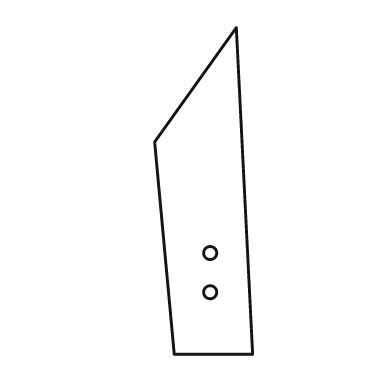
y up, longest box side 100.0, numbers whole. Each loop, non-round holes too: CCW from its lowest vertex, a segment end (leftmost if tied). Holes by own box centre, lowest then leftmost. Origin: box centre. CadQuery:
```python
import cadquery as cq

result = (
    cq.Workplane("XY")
    .moveTo(-9.0, -50.0)
    .lineTo(15.0, -50.0)
    .lineTo(10.0, 50.0)
    .lineTo(-15.0, 15.0)
    .close()
    .moveTo(2.0, -31.0)
    .circle(2.0)
    .moveTo(2.0, -19.0)
    .circle(2.0)
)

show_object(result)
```